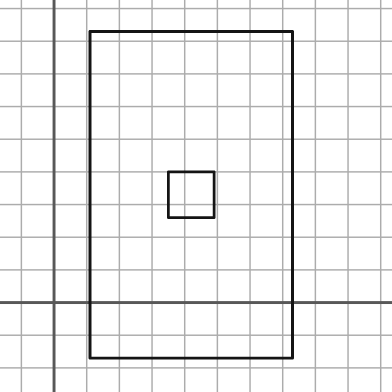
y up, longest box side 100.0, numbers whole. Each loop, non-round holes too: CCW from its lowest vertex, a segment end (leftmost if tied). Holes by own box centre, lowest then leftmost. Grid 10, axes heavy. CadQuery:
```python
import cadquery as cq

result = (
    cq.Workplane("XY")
    .moveTo(11.0, -17.0)
    .lineTo(73.0, -17.0)
    .lineTo(73.0, 83.0)
    .lineTo(11.0, 83.0)
    .close()
    .moveTo(35.0, 26.0)
    .lineTo(49.0, 26.0)
    .lineTo(49.0, 40.0)
    .lineTo(35.0, 40.0)
    .close()
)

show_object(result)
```